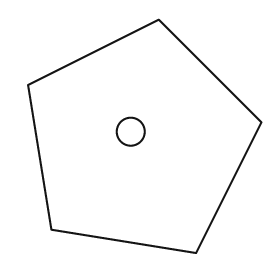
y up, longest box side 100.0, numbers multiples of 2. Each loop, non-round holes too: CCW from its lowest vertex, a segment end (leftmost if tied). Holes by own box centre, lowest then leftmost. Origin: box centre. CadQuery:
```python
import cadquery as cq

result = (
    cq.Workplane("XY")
    .moveTo(22.0, -50.0)
    .lineTo(50.0, 6.0)
    .lineTo(6.0, 50.0)
    .lineTo(-50.0, 22.0)
    .lineTo(-40.0, -40.0)
    .close()
    .moveTo(-6.0, 2.0)
    .circle(6.0)
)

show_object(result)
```